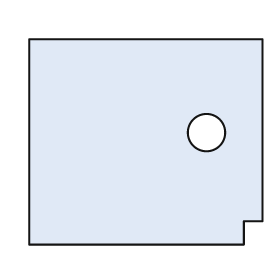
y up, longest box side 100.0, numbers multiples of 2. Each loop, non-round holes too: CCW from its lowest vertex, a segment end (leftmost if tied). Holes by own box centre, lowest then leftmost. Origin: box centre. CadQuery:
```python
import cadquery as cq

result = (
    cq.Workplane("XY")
    .moveTo(-50.0, -44.0)
    .lineTo(42.0, -44.0)
    .lineTo(42.0, -34.0)
    .lineTo(50.0, -34.0)
    .lineTo(50.0, 44.0)
    .lineTo(-50.0, 44.0)
    .close()
    .moveTo(26.0, 4.0)
    .circle(8.0)
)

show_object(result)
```